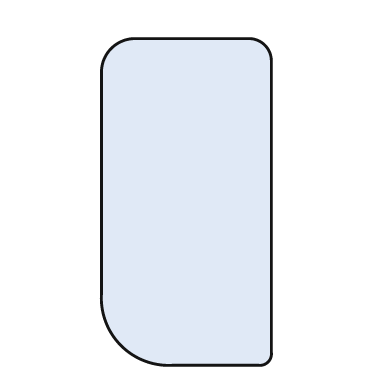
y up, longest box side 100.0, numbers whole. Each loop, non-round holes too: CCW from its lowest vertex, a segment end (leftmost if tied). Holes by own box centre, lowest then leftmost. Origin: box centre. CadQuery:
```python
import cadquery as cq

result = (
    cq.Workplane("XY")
    .moveTo(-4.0, -50.0)
    .lineTo(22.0, -50.0)
    .threePointArc((25.0, -49.0), (26.0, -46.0))
    .lineTo(26.0, 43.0)
    .threePointArc((24.0, 48.0), (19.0, 50.0))
    .lineTo(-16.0, 50.0)
    .threePointArc((-23.0, 47.0), (-26.0, 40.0))
    .lineTo(-26.0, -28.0)
    .threePointArc((-20.0, -44.0), (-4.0, -50.0))
    .close()
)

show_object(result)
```